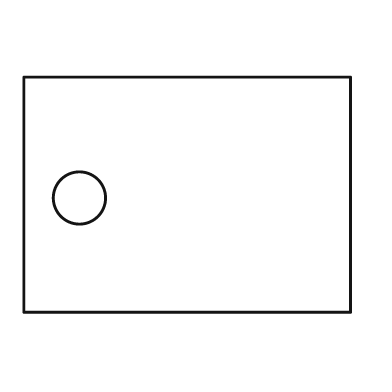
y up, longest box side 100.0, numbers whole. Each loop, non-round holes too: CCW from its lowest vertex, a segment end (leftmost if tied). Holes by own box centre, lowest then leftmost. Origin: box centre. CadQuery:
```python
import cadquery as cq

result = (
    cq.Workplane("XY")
    .moveTo(-50.0, -36.0)
    .lineTo(50.0, -36.0)
    .lineTo(50.0, 36.0)
    .lineTo(-50.0, 36.0)
    .close()
    .moveTo(-33.0, -1.0)
    .circle(8.0)
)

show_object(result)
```